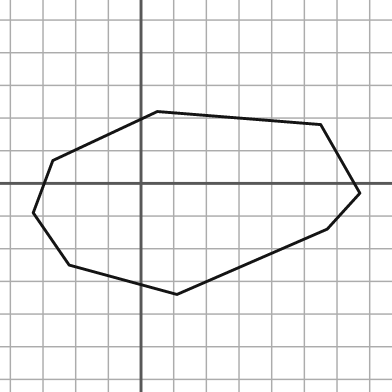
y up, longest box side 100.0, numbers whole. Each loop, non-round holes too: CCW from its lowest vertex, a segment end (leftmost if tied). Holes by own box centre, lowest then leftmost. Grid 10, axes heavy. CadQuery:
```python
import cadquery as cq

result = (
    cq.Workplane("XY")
    .moveTo(11.0, -34.0)
    .lineTo(57.0, -14.0)
    .lineTo(67.0, -3.0)
    .lineTo(55.0, 18.0)
    .lineTo(5.0, 22.0)
    .lineTo(-27.0, 7.0)
    .lineTo(-33.0, -9.0)
    .lineTo(-22.0, -25.0)
    .close()
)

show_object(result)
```